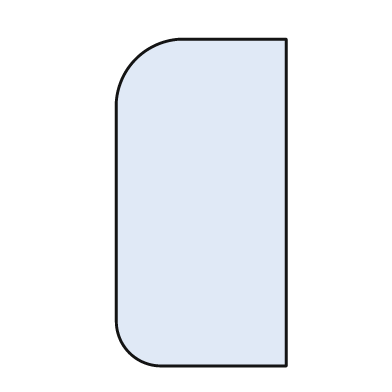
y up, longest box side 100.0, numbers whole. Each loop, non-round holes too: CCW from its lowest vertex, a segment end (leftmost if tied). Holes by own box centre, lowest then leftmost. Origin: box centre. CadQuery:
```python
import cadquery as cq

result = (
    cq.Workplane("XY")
    .moveTo(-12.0, -50.0)
    .lineTo(26.0, -50.0)
    .lineTo(26.0, 50.0)
    .lineTo(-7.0, 50.0)
    .threePointArc((-20.0, 44.0), (-26.0, 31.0))
    .lineTo(-26.0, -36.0)
    .threePointArc((-22.0, -46.0), (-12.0, -50.0))
    .close()
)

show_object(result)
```